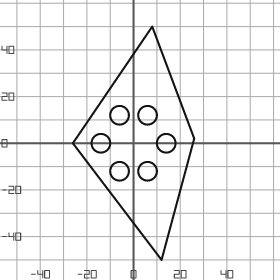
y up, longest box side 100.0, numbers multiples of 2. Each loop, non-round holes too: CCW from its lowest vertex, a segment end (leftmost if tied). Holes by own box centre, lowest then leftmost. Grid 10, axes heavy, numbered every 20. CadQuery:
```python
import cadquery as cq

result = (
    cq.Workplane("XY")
    .moveTo(12.0, -50.0)
    .lineTo(26.0, 2.0)
    .lineTo(8.0, 50.0)
    .lineTo(-26.0, 0.0)
    .close()
    .moveTo(-6.0, -12.0)
    .circle(4.0)
    .moveTo(6.0, -12.0)
    .circle(4.0)
    .moveTo(-14.0, 0.0)
    .circle(4.0)
    .moveTo(14.0, 0.0)
    .circle(4.0)
    .moveTo(-6.0, 12.0)
    .circle(4.0)
    .moveTo(6.0, 12.0)
    .circle(4.0)
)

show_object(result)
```